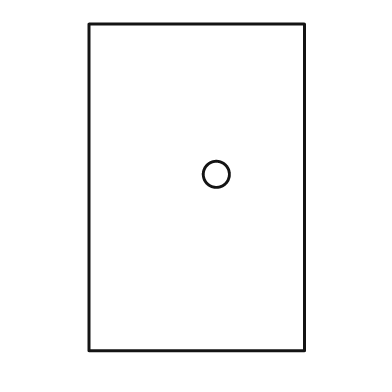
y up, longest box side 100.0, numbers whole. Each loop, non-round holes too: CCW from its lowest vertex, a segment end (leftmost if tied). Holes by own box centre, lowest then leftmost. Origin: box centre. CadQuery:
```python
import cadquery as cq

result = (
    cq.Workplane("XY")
    .moveTo(-33.0, -50.0)
    .lineTo(33.0, -50.0)
    .lineTo(33.0, 50.0)
    .lineTo(-33.0, 50.0)
    .close()
    .moveTo(6.0, 4.0)
    .circle(4.0)
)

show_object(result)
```